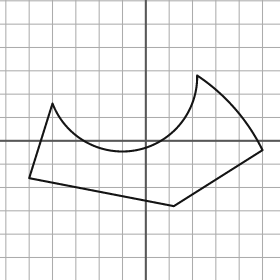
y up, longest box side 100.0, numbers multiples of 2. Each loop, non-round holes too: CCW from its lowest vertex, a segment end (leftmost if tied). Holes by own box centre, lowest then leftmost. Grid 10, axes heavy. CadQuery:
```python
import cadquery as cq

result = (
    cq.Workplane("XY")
    .moveTo(12.0, -28.0)
    .lineTo(50.0, -4.0)
    .threePointArc((38.0, 14.0), (22.0, 28.0))
    .threePointArc((-4.0, -4.0), (-40.0, 16.0))
    .lineTo(-50.0, -16.0)
    .close()
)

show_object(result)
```